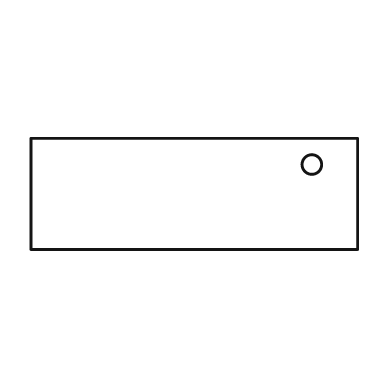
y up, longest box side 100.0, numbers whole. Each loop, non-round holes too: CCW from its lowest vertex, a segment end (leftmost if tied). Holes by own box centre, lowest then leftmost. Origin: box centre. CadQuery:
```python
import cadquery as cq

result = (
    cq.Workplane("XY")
    .moveTo(-50.0, -17.0)
    .lineTo(50.0, -17.0)
    .lineTo(50.0, 17.0)
    .lineTo(-50.0, 17.0)
    .close()
    .moveTo(36.0, 9.0)
    .circle(3.0)
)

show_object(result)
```